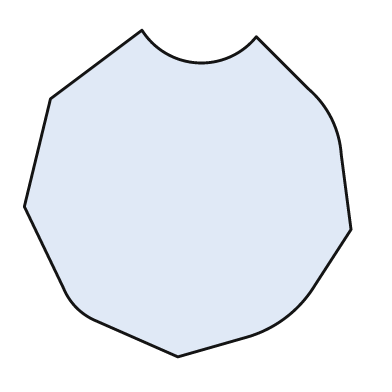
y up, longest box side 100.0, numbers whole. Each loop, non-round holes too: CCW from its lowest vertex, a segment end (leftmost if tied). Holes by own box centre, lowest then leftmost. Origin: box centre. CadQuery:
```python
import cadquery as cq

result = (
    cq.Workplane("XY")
    .moveTo(-3.0, -50.0)
    .lineTo(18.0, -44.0)
    .threePointArc((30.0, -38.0), (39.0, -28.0))
    .lineTo(50.0, -11.0)
    .lineTo(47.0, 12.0)
    .threePointArc((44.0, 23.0), (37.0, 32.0))
    .lineTo(21.0, 48.0)
    .threePointArc((3.0, 40.0), (-14.0, 50.0))
    .lineTo(-42.0, 29.0)
    .lineTo(-50.0, -4.0)
    .lineTo(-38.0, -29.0)
    .threePointArc((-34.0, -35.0), (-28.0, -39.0))
    .close()
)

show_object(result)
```